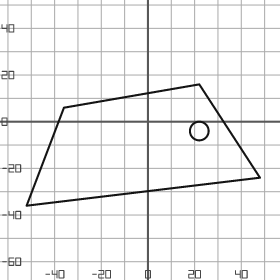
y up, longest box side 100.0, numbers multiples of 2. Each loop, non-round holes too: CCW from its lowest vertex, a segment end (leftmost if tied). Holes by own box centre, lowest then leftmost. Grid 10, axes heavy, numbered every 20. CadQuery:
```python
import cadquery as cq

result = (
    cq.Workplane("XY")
    .moveTo(-52.0, -36.0)
    .lineTo(48.0, -24.0)
    .lineTo(22.0, 16.0)
    .lineTo(-36.0, 6.0)
    .close()
    .moveTo(22.0, -4.0)
    .circle(4.0)
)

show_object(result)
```